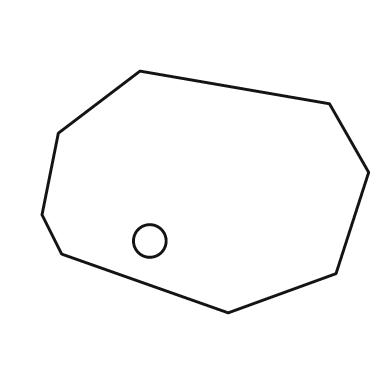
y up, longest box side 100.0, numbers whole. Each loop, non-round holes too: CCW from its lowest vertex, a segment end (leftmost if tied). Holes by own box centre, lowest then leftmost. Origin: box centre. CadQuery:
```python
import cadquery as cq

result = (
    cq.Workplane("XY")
    .moveTo(7.0, -37.0)
    .lineTo(40.0, -25.0)
    .lineTo(50.0, 6.0)
    .lineTo(38.0, 27.0)
    .lineTo(-20.0, 37.0)
    .lineTo(-45.0, 18.0)
    .lineTo(-50.0, -7.0)
    .lineTo(-44.0, -19.0)
    .close()
    .moveTo(-17.0, -15.0)
    .circle(5.0)
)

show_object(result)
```